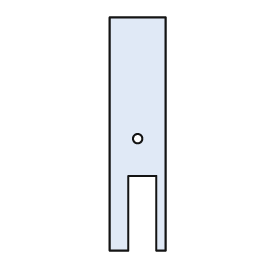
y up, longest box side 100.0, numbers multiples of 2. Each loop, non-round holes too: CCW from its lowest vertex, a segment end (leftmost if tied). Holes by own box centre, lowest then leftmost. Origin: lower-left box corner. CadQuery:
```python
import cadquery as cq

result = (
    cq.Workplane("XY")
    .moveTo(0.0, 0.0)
    .lineTo(8.0, 0.0)
    .lineTo(8.0, 32.0)
    .lineTo(20.0, 32.0)
    .lineTo(20.0, 0.0)
    .lineTo(24.0, 0.0)
    .lineTo(24.0, 100.0)
    .lineTo(0.0, 100.0)
    .close()
    .moveTo(12.0, 48.0)
    .circle(2.0)
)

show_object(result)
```